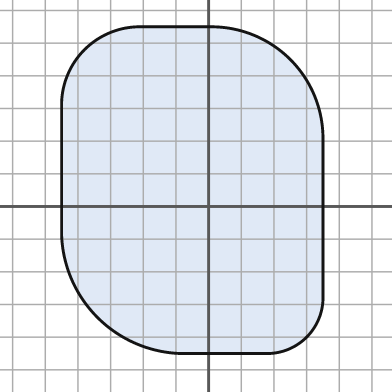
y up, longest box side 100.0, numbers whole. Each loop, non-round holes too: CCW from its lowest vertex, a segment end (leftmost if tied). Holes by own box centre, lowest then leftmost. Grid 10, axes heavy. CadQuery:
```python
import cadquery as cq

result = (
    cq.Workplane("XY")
    .moveTo(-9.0, -45.0)
    .lineTo(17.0, -45.0)
    .threePointArc((30.0, -40.0), (35.0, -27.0))
    .lineTo(35.0, 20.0)
    .threePointArc((25.0, 45.0), (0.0, 55.0))
    .lineTo(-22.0, 55.0)
    .threePointArc((-38.0, 48.0), (-45.0, 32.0))
    .lineTo(-45.0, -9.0)
    .threePointArc((-34.0, -34.0), (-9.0, -45.0))
    .close()
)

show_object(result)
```